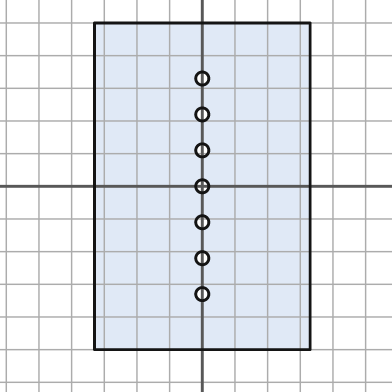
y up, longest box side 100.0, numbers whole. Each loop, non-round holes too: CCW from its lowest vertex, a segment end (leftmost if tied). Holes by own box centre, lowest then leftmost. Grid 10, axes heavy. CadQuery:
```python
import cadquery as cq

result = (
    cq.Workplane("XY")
    .moveTo(-33.0, -50.0)
    .lineTo(33.0, -50.0)
    .lineTo(33.0, 50.0)
    .lineTo(-33.0, 50.0)
    .close()
    .moveTo(0.0, -33.0)
    .circle(2.0)
    .moveTo(0.0, -22.0)
    .circle(2.0)
    .moveTo(0.0, -11.0)
    .circle(2.0)
    .moveTo(0.0, 0.0)
    .circle(2.0)
    .moveTo(0.0, 11.0)
    .circle(2.0)
    .moveTo(0.0, 22.0)
    .circle(2.0)
    .moveTo(0.0, 33.0)
    .circle(2.0)
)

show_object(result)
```